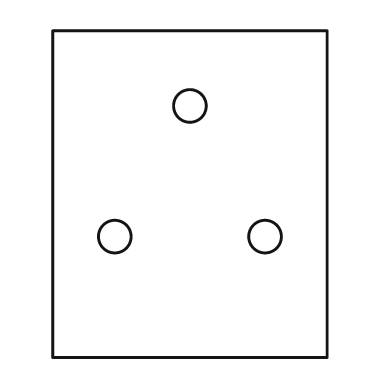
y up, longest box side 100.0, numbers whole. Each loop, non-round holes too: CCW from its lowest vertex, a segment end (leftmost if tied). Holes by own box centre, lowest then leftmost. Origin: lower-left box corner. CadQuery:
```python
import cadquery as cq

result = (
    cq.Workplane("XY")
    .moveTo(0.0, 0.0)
    .lineTo(84.0, 0.0)
    .lineTo(84.0, 100.0)
    .lineTo(0.0, 100.0)
    .close()
    .moveTo(19.0, 37.0)
    .circle(5.0)
    .moveTo(65.0, 37.0)
    .circle(5.0)
    .moveTo(42.0, 77.0)
    .circle(5.0)
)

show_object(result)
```